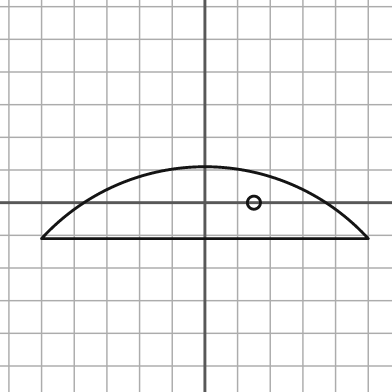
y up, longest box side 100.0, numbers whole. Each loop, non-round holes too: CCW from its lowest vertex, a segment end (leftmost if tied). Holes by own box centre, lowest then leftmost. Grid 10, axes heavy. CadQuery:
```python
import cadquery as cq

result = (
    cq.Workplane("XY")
    .moveTo(-50.0, -11.0)
    .lineTo(50.0, -11.0)
    .threePointArc((0.0, 11.0), (-50.0, -11.0))
    .close()
    .moveTo(15.0, 0.0)
    .circle(2.0)
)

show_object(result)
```